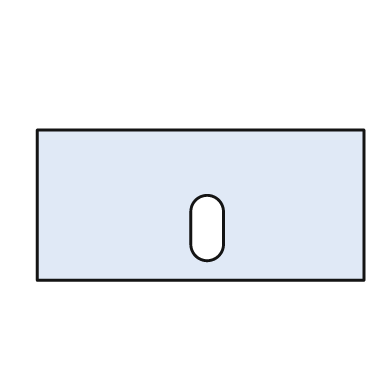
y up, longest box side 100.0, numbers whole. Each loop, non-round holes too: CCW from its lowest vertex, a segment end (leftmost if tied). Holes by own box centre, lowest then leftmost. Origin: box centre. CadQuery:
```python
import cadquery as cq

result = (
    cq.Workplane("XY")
    .moveTo(-50.0, -23.0)
    .lineTo(50.0, -23.0)
    .lineTo(50.0, 23.0)
    .lineTo(-50.0, 23.0)
    .close()
    .moveTo(-3.0, -12.0)
    .threePointArc((2.0, -17.0), (7.0, -12.0))
    .lineTo(7.0, -2.0)
    .threePointArc((2.0, 3.0), (-3.0, -2.0))
    .close()
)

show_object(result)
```